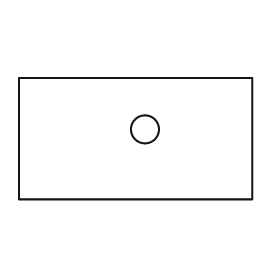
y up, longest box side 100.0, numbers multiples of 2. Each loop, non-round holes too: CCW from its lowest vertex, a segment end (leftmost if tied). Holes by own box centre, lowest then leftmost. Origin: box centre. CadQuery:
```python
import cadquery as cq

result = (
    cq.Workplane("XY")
    .moveTo(-50.0, -26.0)
    .lineTo(50.0, -26.0)
    .lineTo(50.0, 26.0)
    .lineTo(-50.0, 26.0)
    .close()
    .moveTo(4.0, 4.0)
    .circle(6.0)
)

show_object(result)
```